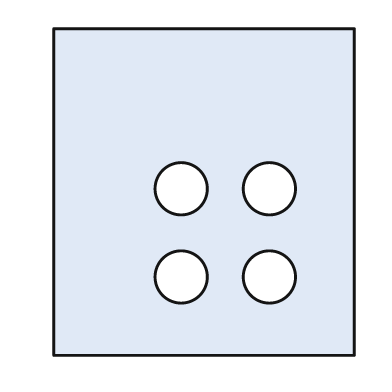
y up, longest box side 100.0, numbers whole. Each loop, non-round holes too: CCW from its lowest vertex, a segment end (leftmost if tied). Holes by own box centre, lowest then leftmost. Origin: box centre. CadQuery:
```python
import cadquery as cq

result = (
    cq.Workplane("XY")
    .moveTo(-46.0, -50.0)
    .lineTo(46.0, -50.0)
    .lineTo(46.0, 50.0)
    .lineTo(-46.0, 50.0)
    .close()
    .moveTo(-7.0, -26.0)
    .circle(8.0)
    .moveTo(20.0, -26.0)
    .circle(8.0)
    .moveTo(-7.0, 1.0)
    .circle(8.0)
    .moveTo(20.0, 1.0)
    .circle(8.0)
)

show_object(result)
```